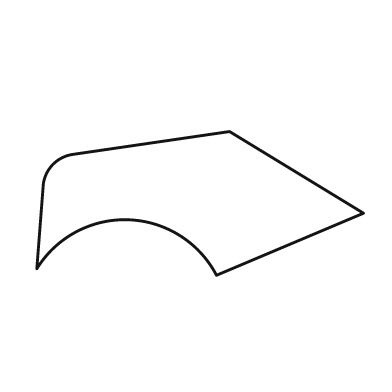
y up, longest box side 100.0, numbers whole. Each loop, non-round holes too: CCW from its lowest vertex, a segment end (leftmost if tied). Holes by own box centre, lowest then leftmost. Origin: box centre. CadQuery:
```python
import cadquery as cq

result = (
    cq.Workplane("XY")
    .moveTo(5.0, -22.0)
    .lineTo(50.0, -3.0)
    .lineTo(9.0, 22.0)
    .lineTo(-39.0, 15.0)
    .threePointArc((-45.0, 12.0), (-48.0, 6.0))
    .lineTo(-50.0, -20.0)
    .threePointArc((-22.0, -5.0), (5.0, -22.0))
    .close()
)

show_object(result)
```